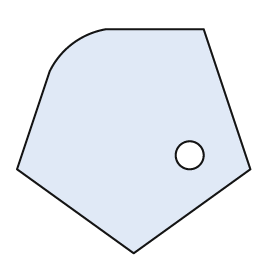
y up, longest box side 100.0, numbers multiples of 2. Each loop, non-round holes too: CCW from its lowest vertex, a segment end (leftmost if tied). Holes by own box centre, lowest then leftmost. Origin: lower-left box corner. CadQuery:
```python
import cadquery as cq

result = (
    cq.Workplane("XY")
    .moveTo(50.0, 0.0)
    .lineTo(100.0, 36.0)
    .lineTo(80.0, 96.0)
    .lineTo(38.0, 96.0)
    .threePointArc((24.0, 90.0), (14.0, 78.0))
    .lineTo(0.0, 36.0)
    .close()
    .moveTo(74.0, 42.0)
    .circle(6.0)
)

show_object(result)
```